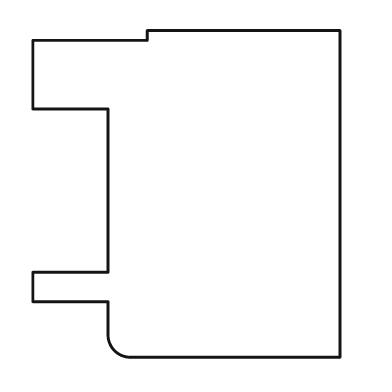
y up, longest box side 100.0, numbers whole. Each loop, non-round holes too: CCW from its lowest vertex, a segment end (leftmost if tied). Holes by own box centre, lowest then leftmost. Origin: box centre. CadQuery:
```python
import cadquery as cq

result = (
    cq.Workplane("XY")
    .moveTo(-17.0, -50.0)
    .lineTo(47.0, -50.0)
    .lineTo(47.0, 50.0)
    .lineTo(-12.0, 50.0)
    .lineTo(-12.0, 47.0)
    .lineTo(-47.0, 47.0)
    .lineTo(-47.0, 26.0)
    .lineTo(-24.0, 26.0)
    .lineTo(-24.0, -24.0)
    .lineTo(-47.0, -24.0)
    .lineTo(-47.0, -33.0)
    .lineTo(-24.0, -33.0)
    .lineTo(-24.0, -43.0)
    .threePointArc((-22.0, -48.0), (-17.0, -50.0))
    .close()
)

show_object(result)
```